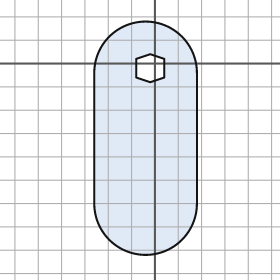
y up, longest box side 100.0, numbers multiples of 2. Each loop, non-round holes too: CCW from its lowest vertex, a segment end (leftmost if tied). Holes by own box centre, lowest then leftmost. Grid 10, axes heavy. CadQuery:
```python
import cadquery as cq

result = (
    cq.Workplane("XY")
    .moveTo(-26.0, -60.0)
    .threePointArc((-4.0, -82.0), (18.0, -60.0))
    .lineTo(18.0, -4.0)
    .threePointArc((-4.0, 18.0), (-26.0, -4.0))
    .close()
    .moveTo(-2.0, -8.0)
    .lineTo(4.0, -6.0)
    .lineTo(4.0, 2.0)
    .lineTo(-2.0, 4.0)
    .lineTo(-8.0, 2.0)
    .lineTo(-8.0, -6.0)
    .close()
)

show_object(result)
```